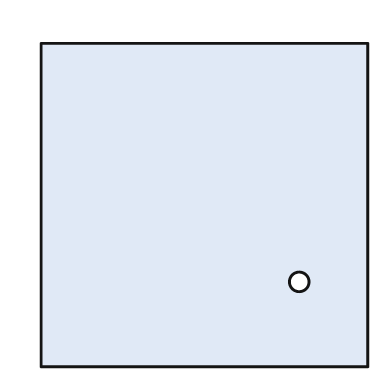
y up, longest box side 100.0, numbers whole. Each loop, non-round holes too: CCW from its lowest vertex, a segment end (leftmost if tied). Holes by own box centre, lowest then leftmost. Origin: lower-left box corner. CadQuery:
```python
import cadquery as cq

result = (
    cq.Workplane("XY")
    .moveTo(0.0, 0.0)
    .lineTo(100.0, 0.0)
    .lineTo(100.0, 99.0)
    .lineTo(0.0, 99.0)
    .close()
    .moveTo(79.0, 26.0)
    .circle(3.0)
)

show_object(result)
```